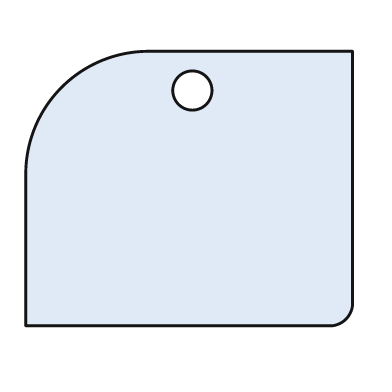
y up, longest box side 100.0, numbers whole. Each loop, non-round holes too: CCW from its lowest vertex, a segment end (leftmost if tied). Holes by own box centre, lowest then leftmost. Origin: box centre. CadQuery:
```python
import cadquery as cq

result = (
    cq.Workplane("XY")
    .moveTo(-50.0, -42.0)
    .lineTo(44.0, -42.0)
    .threePointArc((48.0, -40.0), (50.0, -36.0))
    .lineTo(50.0, 42.0)
    .lineTo(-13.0, 42.0)
    .threePointArc((-39.0, 31.0), (-50.0, 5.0))
    .close()
    .moveTo(1.0, 30.0)
    .circle(6.0)
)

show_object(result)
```